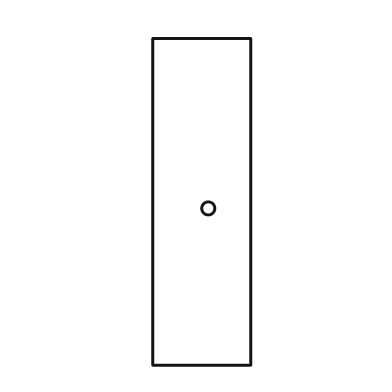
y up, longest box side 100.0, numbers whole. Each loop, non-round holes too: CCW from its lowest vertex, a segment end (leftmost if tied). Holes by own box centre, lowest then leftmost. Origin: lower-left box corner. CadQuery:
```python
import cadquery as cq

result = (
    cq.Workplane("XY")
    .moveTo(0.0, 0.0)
    .lineTo(30.0, 0.0)
    .lineTo(30.0, 100.0)
    .lineTo(0.0, 100.0)
    .close()
    .moveTo(17.0, 48.0)
    .circle(2.0)
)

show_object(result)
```